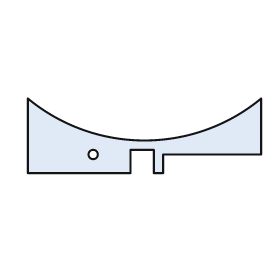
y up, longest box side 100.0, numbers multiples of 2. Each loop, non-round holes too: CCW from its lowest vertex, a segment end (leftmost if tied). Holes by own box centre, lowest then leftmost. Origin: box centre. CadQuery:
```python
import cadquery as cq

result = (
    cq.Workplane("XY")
    .moveTo(-50.0, -16.0)
    .lineTo(-6.0, -16.0)
    .lineTo(-6.0, -6.0)
    .lineTo(4.0, -6.0)
    .lineTo(4.0, -16.0)
    .lineTo(8.0, -16.0)
    .lineTo(8.0, -8.0)
    .lineTo(50.0, -8.0)
    .lineTo(50.0, 16.0)
    .threePointArc((0.0, -2.0), (-50.0, 16.0))
    .close()
    .moveTo(-22.0, -8.0)
    .circle(2.0)
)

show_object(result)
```